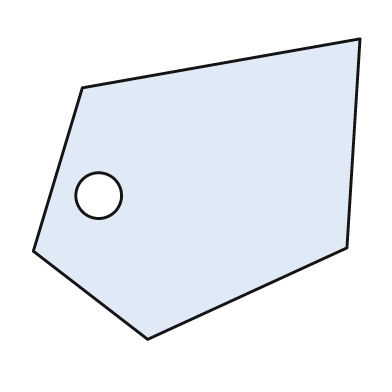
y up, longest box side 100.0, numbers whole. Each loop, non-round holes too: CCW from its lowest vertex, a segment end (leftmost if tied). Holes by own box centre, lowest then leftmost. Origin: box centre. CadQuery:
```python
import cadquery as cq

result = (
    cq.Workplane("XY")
    .moveTo(-15.0, -46.0)
    .lineTo(46.0, -18.0)
    .lineTo(50.0, 46.0)
    .lineTo(-35.0, 31.0)
    .lineTo(-50.0, -19.0)
    .close()
    .moveTo(-30.0, -2.0)
    .circle(7.0)
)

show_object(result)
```